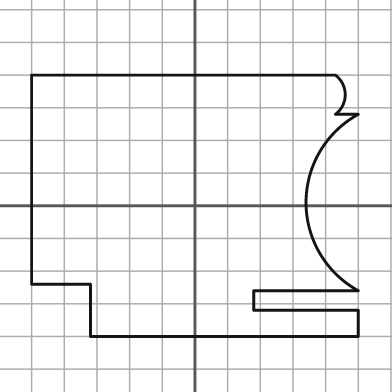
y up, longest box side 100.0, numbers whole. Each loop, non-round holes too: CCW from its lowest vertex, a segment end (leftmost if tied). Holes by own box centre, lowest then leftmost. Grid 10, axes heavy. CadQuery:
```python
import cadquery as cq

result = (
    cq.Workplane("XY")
    .moveTo(-32.0, -40.0)
    .lineTo(50.0, -40.0)
    .lineTo(50.0, -32.0)
    .lineTo(18.0, -32.0)
    .lineTo(18.0, -26.0)
    .lineTo(50.0, -26.0)
    .threePointArc((34.0, 1.0), (50.0, 28.0))
    .lineTo(43.0, 28.0)
    .threePointArc((46.0, 34.0), (43.0, 40.0))
    .lineTo(-50.0, 40.0)
    .lineTo(-50.0, -24.0)
    .lineTo(-32.0, -24.0)
    .close()
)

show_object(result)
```